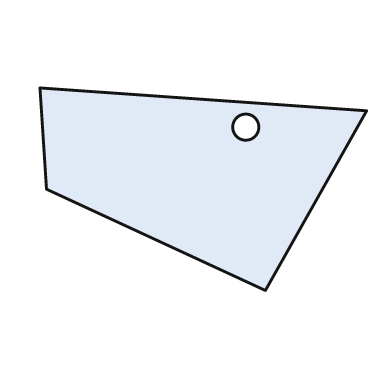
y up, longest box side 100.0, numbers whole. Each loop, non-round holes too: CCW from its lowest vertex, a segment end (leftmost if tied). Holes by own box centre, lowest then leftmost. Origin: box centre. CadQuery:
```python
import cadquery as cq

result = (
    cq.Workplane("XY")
    .moveTo(19.0, -31.0)
    .lineTo(50.0, 24.0)
    .lineTo(-50.0, 31.0)
    .lineTo(-48.0, 0.0)
    .close()
    .moveTo(13.0, 19.0)
    .circle(4.0)
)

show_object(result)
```